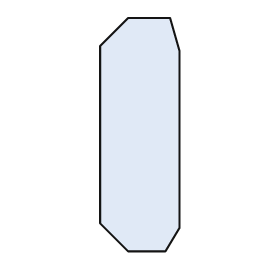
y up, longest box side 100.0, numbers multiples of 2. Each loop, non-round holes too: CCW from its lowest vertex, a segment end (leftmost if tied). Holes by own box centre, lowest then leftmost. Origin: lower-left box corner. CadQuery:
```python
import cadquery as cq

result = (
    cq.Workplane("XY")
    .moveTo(12.0, 0.0)
    .lineTo(28.0, 0.0)
    .lineTo(34.0, 10.0)
    .lineTo(34.0, 86.0)
    .lineTo(30.0, 100.0)
    .lineTo(12.0, 100.0)
    .lineTo(0.0, 88.0)
    .lineTo(0.0, 12.0)
    .close()
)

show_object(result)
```